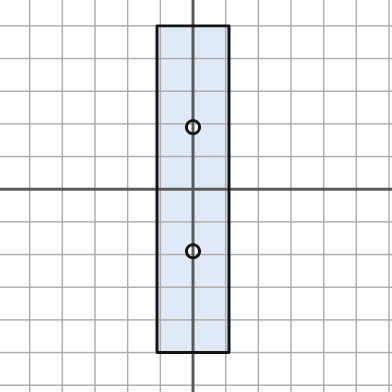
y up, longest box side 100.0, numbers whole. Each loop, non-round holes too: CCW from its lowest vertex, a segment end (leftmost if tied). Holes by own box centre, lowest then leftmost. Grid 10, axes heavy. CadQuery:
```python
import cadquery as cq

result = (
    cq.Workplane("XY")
    .moveTo(-11.0, -50.0)
    .lineTo(11.0, -50.0)
    .lineTo(11.0, 50.0)
    .lineTo(-11.0, 50.0)
    .close()
    .moveTo(0.0, -19.0)
    .circle(2.0)
    .moveTo(0.0, 19.0)
    .circle(2.0)
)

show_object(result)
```